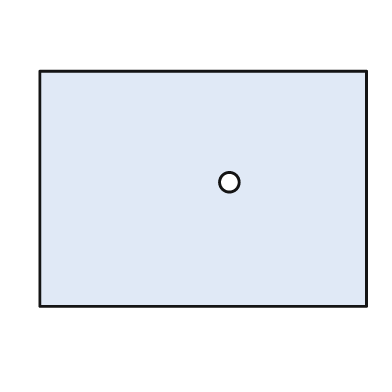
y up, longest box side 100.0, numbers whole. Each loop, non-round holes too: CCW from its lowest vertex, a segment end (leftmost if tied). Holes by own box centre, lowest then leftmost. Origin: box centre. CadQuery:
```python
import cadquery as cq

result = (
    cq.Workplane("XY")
    .moveTo(-50.0, -36.0)
    .lineTo(50.0, -36.0)
    .lineTo(50.0, 36.0)
    .lineTo(-50.0, 36.0)
    .close()
    .moveTo(8.0, 2.0)
    .circle(3.0)
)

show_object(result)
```